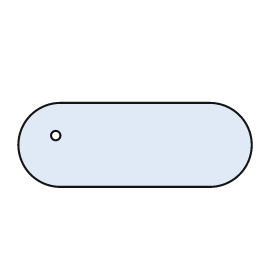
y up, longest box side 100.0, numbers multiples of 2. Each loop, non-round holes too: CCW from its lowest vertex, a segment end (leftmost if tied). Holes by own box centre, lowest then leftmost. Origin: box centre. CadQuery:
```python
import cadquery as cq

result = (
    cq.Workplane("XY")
    .moveTo(-32.0, -18.0)
    .lineTo(32.0, -18.0)
    .threePointArc((50.0, 0.0), (32.0, 18.0))
    .lineTo(-32.0, 18.0)
    .threePointArc((-50.0, 0.0), (-32.0, -18.0))
    .close()
    .moveTo(-34.0, 4.0)
    .circle(2.0)
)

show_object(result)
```